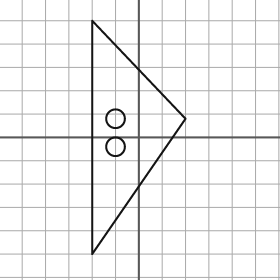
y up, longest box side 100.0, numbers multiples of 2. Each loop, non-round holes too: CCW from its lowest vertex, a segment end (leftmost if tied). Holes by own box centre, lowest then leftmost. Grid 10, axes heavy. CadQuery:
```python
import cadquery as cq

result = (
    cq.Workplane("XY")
    .moveTo(-20.0, -50.0)
    .lineTo(20.0, 8.0)
    .lineTo(-20.0, 50.0)
    .close()
    .moveTo(-10.0, -4.0)
    .circle(4.0)
    .moveTo(-10.0, 8.0)
    .circle(4.0)
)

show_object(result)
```